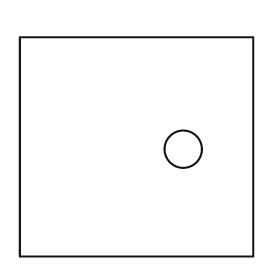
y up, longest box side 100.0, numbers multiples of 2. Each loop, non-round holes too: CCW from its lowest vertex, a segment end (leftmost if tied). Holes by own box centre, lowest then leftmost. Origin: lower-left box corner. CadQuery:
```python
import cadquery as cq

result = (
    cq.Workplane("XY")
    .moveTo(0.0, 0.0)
    .lineTo(100.0, 0.0)
    .lineTo(100.0, 94.0)
    .lineTo(0.0, 94.0)
    .close()
    .moveTo(70.0, 46.0)
    .circle(8.0)
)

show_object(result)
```